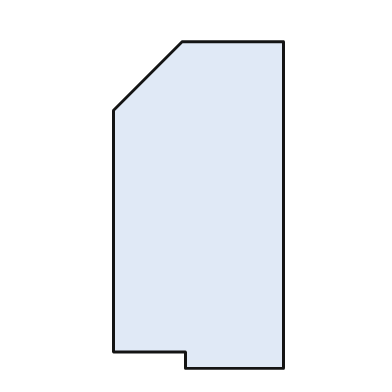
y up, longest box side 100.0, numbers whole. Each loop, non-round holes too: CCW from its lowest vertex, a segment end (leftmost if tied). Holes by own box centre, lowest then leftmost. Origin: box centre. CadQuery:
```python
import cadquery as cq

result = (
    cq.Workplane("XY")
    .moveTo(-4.0, -50.0)
    .lineTo(26.0, -50.0)
    .lineTo(26.0, 50.0)
    .lineTo(-5.0, 50.0)
    .lineTo(-26.0, 29.0)
    .lineTo(-26.0, -45.0)
    .lineTo(-4.0, -45.0)
    .close()
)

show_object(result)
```